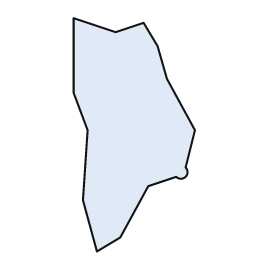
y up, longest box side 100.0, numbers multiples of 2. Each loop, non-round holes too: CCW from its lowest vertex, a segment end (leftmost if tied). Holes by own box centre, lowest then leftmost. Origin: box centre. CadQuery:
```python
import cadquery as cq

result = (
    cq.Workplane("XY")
    .moveTo(-16.0, -50.0)
    .lineTo(-6.0, -44.0)
    .lineTo(6.0, -22.0)
    .lineTo(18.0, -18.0)
    .threePointArc((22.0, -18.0), (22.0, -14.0))
    .lineTo(26.0, 2.0)
    .lineTo(14.0, 24.0)
    .lineTo(10.0, 38.0)
    .lineTo(4.0, 48.0)
    .lineTo(-8.0, 44.0)
    .lineTo(-26.0, 50.0)
    .lineTo(-26.0, 18.0)
    .lineTo(-20.0, 2.0)
    .lineTo(-22.0, -28.0)
    .close()
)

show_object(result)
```